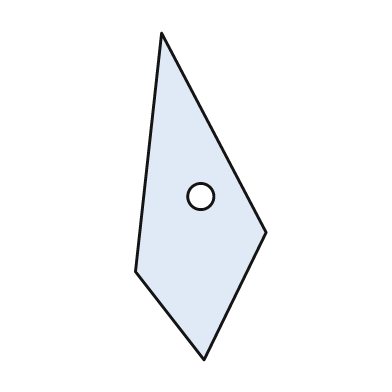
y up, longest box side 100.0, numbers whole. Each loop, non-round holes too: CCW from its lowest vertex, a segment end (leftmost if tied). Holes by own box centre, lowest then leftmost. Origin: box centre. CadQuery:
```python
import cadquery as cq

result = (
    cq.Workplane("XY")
    .moveTo(1.0, -50.0)
    .lineTo(20.0, -11.0)
    .lineTo(-12.0, 50.0)
    .lineTo(-20.0, -23.0)
    .close()
    .moveTo(0.0, 0.0)
    .circle(4.0)
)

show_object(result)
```